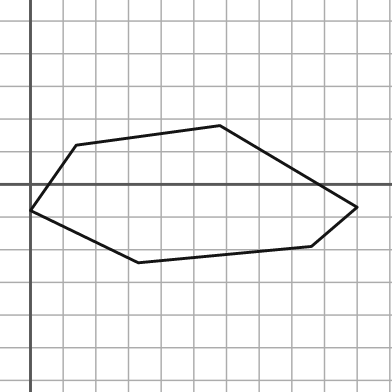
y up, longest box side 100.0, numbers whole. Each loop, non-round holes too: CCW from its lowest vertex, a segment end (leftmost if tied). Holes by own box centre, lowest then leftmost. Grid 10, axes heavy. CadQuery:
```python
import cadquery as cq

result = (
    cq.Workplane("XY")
    .moveTo(33.0, -24.0)
    .lineTo(86.0, -19.0)
    .lineTo(100.0, -7.0)
    .lineTo(58.0, 18.0)
    .lineTo(14.0, 12.0)
    .lineTo(0.0, -8.0)
    .close()
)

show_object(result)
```